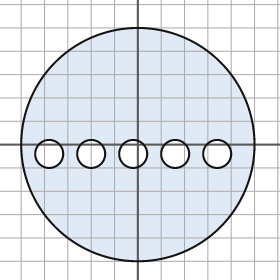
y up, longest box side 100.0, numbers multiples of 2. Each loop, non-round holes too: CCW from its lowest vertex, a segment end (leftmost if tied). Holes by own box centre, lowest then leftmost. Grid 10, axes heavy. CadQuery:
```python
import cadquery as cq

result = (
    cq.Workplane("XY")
    .moveTo(0.0, 0.0)
    .circle(50.0)
    .moveTo(-38.0, -4.0)
    .circle(6.0)
    .moveTo(-20.0, -4.0)
    .circle(6.0)
    .moveTo(-2.0, -4.0)
    .circle(6.0)
    .moveTo(16.0, -4.0)
    .circle(6.0)
    .moveTo(34.0, -4.0)
    .circle(6.0)
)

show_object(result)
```